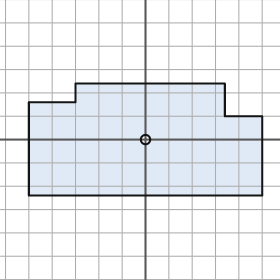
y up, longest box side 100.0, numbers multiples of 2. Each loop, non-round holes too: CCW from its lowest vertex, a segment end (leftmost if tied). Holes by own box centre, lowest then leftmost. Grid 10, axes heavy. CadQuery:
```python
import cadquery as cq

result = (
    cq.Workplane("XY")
    .moveTo(-50.0, -24.0)
    .lineTo(50.0, -24.0)
    .lineTo(50.0, 10.0)
    .lineTo(34.0, 10.0)
    .lineTo(34.0, 24.0)
    .lineTo(-30.0, 24.0)
    .lineTo(-30.0, 16.0)
    .lineTo(-50.0, 16.0)
    .close()
    .moveTo(0.0, 0.0)
    .circle(2.0)
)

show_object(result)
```